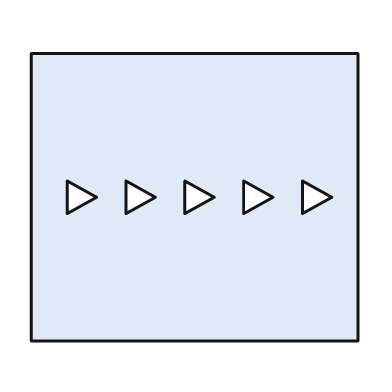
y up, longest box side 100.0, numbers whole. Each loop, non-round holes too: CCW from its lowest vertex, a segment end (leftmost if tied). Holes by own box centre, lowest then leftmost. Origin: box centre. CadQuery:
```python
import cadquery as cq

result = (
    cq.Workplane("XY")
    .moveTo(-50.0, -44.0)
    .lineTo(50.0, -44.0)
    .lineTo(50.0, 44.0)
    .lineTo(-50.0, 44.0)
    .close()
    .moveTo(-39.0, -5.0)
    .lineTo(-30.0, 0.0)
    .lineTo(-39.0, 5.0)
    .close()
    .moveTo(-21.0, -5.0)
    .lineTo(-12.0, 0.0)
    .lineTo(-21.0, 5.0)
    .close()
    .moveTo(-3.0, -5.0)
    .lineTo(6.0, 0.0)
    .lineTo(-3.0, 5.0)
    .close()
    .moveTo(15.0, -5.0)
    .lineTo(24.0, 0.0)
    .lineTo(15.0, 5.0)
    .close()
    .moveTo(33.0, -5.0)
    .lineTo(42.0, 0.0)
    .lineTo(33.0, 5.0)
    .close()
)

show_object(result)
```